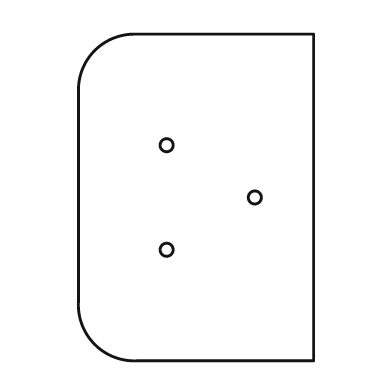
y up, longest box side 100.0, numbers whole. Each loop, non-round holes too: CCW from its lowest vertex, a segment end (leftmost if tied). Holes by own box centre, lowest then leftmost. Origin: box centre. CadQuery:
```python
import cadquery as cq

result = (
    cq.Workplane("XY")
    .moveTo(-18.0, -50.0)
    .lineTo(36.0, -50.0)
    .lineTo(36.0, 50.0)
    .lineTo(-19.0, 50.0)
    .threePointArc((-31.0, 45.0), (-36.0, 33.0))
    .lineTo(-36.0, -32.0)
    .threePointArc((-31.0, -45.0), (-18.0, -50.0))
    .close()
    .moveTo(-9.0, -16.0)
    .circle(2.0)
    .moveTo(18.0, 0.0)
    .circle(2.0)
    .moveTo(-9.0, 16.0)
    .circle(2.0)
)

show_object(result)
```